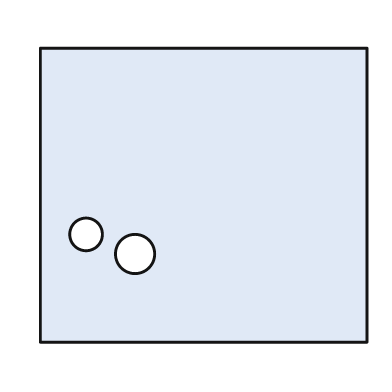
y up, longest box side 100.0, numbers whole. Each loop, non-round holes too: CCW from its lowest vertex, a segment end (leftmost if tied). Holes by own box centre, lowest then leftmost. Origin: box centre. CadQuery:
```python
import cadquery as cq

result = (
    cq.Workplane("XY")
    .moveTo(-50.0, -45.0)
    .lineTo(50.0, -45.0)
    .lineTo(50.0, 45.0)
    .lineTo(-50.0, 45.0)
    .close()
    .moveTo(-21.0, -18.0)
    .circle(6.0)
    .moveTo(-36.0, -12.0)
    .circle(5.0)
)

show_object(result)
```